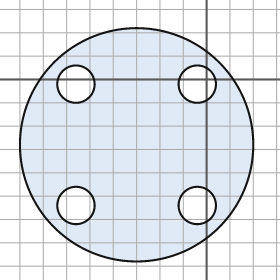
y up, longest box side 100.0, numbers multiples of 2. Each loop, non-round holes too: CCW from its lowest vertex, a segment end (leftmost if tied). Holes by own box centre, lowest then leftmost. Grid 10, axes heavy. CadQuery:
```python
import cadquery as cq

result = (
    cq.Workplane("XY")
    .moveTo(-30.0, -28.0)
    .circle(50.0)
    .moveTo(-56.0, -54.0)
    .circle(8.0)
    .moveTo(-4.0, -54.0)
    .circle(8.0)
    .moveTo(-56.0, -2.0)
    .circle(8.0)
    .moveTo(-4.0, -2.0)
    .circle(8.0)
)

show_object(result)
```